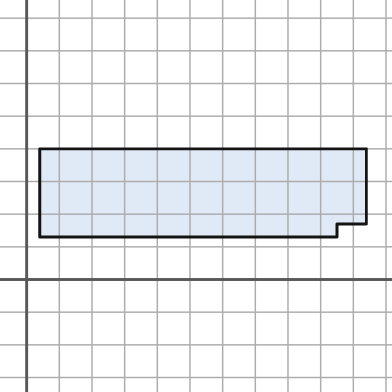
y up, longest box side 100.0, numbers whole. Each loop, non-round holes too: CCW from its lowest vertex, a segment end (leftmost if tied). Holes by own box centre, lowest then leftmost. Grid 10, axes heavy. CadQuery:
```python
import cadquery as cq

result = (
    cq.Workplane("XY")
    .moveTo(4.0, 13.0)
    .lineTo(95.0, 13.0)
    .lineTo(95.0, 17.0)
    .lineTo(104.0, 17.0)
    .lineTo(104.0, 40.0)
    .lineTo(4.0, 40.0)
    .close()
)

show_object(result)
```